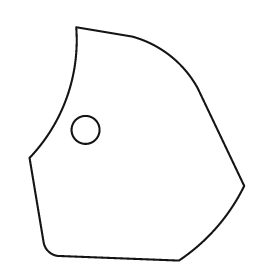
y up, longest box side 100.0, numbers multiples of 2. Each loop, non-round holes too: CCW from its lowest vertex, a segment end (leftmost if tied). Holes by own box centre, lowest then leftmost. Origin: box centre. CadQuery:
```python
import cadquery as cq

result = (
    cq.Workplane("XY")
    .moveTo(18.0, -50.0)
    .threePointArc((34.0, -36.0), (46.0, -18.0))
    .lineTo(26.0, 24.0)
    .threePointArc((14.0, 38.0), (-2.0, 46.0))
    .lineTo(-26.0, 50.0)
    .threePointArc((-30.0, 20.0), (-46.0, -6.0))
    .lineTo(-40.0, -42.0)
    .threePointArc((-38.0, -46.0), (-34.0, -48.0))
    .close()
    .moveTo(-22.0, 6.0)
    .circle(6.0)
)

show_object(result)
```